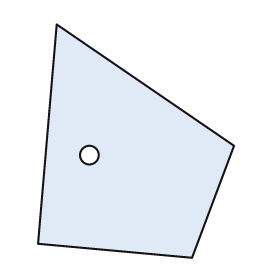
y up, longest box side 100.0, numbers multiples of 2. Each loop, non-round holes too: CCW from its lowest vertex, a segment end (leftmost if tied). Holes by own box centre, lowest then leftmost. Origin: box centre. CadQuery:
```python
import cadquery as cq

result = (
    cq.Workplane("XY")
    .moveTo(24.0, -50.0)
    .lineTo(42.0, -2.0)
    .lineTo(-34.0, 50.0)
    .lineTo(-42.0, -44.0)
    .close()
    .moveTo(-20.0, -6.0)
    .circle(4.0)
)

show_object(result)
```